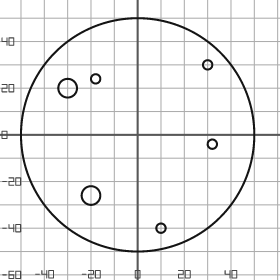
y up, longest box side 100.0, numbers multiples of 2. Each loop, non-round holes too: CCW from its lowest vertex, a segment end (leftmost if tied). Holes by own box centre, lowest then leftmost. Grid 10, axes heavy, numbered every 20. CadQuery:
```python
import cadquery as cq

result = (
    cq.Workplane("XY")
    .moveTo(0.0, 0.0)
    .circle(50.0)
    .moveTo(10.0, -40.0)
    .circle(2.0)
    .moveTo(-20.0, -26.0)
    .circle(4.0)
    .moveTo(32.0, -4.0)
    .circle(2.0)
    .moveTo(-30.0, 20.0)
    .circle(4.0)
    .moveTo(-18.0, 24.0)
    .circle(2.0)
    .moveTo(30.0, 30.0)
    .circle(2.0)
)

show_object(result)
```